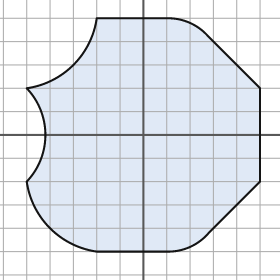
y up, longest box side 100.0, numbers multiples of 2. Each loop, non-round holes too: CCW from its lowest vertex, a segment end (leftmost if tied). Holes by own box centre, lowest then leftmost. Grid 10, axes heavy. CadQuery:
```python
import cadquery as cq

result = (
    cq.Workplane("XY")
    .moveTo(-20.0, -50.0)
    .lineTo(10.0, -50.0)
    .threePointArc((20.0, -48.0), (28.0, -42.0))
    .lineTo(50.0, -20.0)
    .lineTo(50.0, 20.0)
    .lineTo(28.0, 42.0)
    .threePointArc((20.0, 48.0), (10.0, 50.0))
    .lineTo(-20.0, 50.0)
    .threePointArc((-30.0, 30.0), (-50.0, 20.0))
    .threePointArc((-42.0, 0.0), (-50.0, -20.0))
    .threePointArc((-40.0, -40.0), (-20.0, -50.0))
    .close()
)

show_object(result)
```